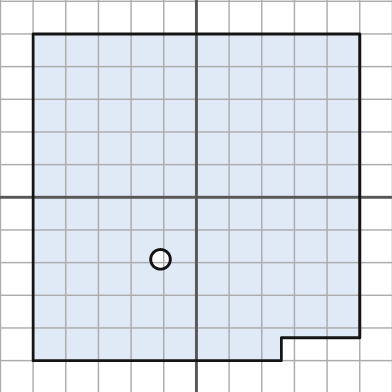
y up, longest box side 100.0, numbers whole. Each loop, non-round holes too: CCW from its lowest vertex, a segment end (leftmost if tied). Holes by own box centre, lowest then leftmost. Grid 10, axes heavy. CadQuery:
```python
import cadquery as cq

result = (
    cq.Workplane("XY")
    .moveTo(-50.0, -50.0)
    .lineTo(26.0, -50.0)
    .lineTo(26.0, -43.0)
    .lineTo(50.0, -43.0)
    .lineTo(50.0, 50.0)
    .lineTo(-50.0, 50.0)
    .close()
    .moveTo(-11.0, -19.0)
    .circle(3.0)
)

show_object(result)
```